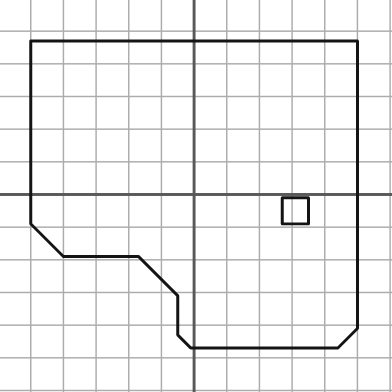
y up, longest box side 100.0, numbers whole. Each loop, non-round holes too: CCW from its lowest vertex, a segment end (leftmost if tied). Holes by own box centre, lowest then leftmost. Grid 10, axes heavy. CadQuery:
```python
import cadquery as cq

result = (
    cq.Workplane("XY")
    .moveTo(-1.0, -47.0)
    .lineTo(44.0, -47.0)
    .lineTo(50.0, -41.0)
    .lineTo(50.0, 47.0)
    .lineTo(-50.0, 47.0)
    .lineTo(-50.0, -9.0)
    .lineTo(-40.0, -19.0)
    .lineTo(-17.0, -19.0)
    .lineTo(-5.0, -31.0)
    .lineTo(-5.0, -43.0)
    .close()
    .moveTo(27.0, -9.0)
    .lineTo(35.0, -9.0)
    .lineTo(35.0, -1.0)
    .lineTo(27.0, -1.0)
    .close()
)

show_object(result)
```